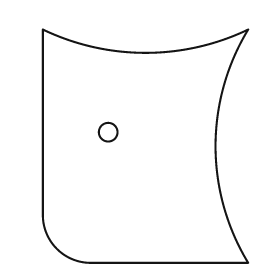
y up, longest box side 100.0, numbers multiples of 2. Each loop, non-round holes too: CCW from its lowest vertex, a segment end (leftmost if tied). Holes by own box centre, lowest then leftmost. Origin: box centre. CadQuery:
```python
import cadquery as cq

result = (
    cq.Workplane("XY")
    .moveTo(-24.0, -50.0)
    .lineTo(44.0, -50.0)
    .threePointArc((30.0, 0.0), (44.0, 50.0))
    .threePointArc((0.0, 40.0), (-44.0, 50.0))
    .lineTo(-44.0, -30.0)
    .threePointArc((-38.0, -44.0), (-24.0, -50.0))
    .close()
    .moveTo(-16.0, 6.0)
    .circle(4.0)
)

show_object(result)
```